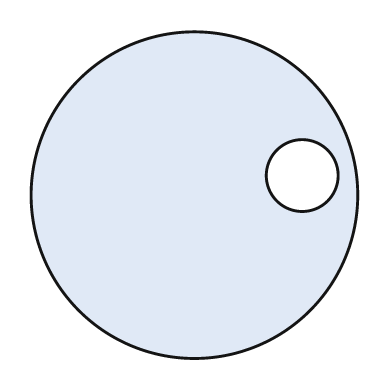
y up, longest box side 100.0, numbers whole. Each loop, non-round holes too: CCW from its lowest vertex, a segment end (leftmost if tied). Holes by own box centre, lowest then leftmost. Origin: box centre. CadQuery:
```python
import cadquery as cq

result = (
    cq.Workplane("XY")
    .moveTo(0.0, 0.0)
    .circle(50.0)
    .moveTo(33.0, 6.0)
    .circle(11.0)
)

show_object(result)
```